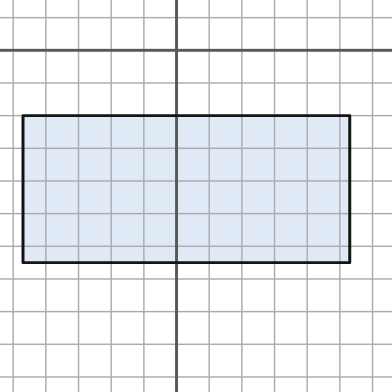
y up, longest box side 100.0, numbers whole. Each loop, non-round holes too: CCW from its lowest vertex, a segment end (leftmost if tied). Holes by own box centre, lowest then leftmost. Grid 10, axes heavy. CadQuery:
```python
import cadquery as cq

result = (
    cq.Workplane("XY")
    .moveTo(-47.0, -65.0)
    .lineTo(53.0, -65.0)
    .lineTo(53.0, -20.0)
    .lineTo(-47.0, -20.0)
    .close()
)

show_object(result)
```